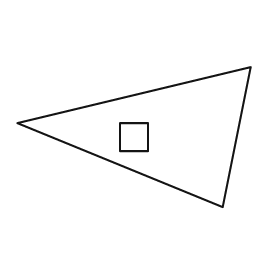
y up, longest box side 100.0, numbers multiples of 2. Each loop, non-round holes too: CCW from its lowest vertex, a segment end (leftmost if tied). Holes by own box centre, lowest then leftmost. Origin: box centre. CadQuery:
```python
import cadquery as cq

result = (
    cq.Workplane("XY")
    .moveTo(38.0, -30.0)
    .lineTo(50.0, 30.0)
    .lineTo(-50.0, 6.0)
    .close()
    .moveTo(-6.0, -6.0)
    .lineTo(6.0, -6.0)
    .lineTo(6.0, 6.0)
    .lineTo(-6.0, 6.0)
    .close()
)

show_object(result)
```